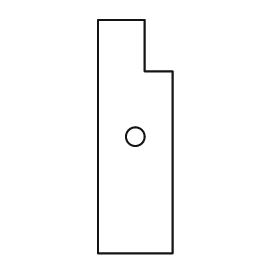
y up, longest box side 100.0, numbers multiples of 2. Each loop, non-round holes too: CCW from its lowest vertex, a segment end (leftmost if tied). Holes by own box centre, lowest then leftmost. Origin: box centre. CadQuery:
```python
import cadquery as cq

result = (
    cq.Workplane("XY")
    .moveTo(-16.0, -50.0)
    .lineTo(16.0, -50.0)
    .lineTo(16.0, 28.0)
    .lineTo(4.0, 28.0)
    .lineTo(4.0, 50.0)
    .lineTo(-16.0, 50.0)
    .close()
    .moveTo(0.0, 0.0)
    .circle(4.0)
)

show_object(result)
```